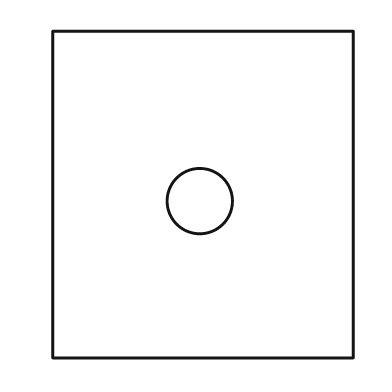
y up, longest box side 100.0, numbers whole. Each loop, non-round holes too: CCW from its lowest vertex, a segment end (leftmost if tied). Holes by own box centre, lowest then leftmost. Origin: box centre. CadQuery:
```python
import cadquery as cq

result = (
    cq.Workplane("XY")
    .moveTo(-46.0, -50.0)
    .lineTo(46.0, -50.0)
    .lineTo(46.0, 50.0)
    .lineTo(-46.0, 50.0)
    .close()
    .moveTo(-1.0, -2.0)
    .circle(10.0)
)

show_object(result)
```